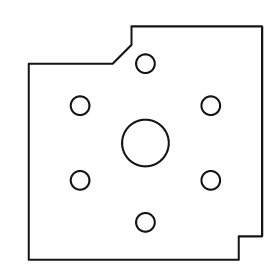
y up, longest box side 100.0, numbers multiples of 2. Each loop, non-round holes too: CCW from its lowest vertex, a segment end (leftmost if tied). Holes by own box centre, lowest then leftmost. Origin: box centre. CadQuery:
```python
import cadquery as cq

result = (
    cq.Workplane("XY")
    .moveTo(-50.0, -50.0)
    .lineTo(40.0, -50.0)
    .lineTo(40.0, -40.0)
    .lineTo(50.0, -40.0)
    .lineTo(50.0, 50.0)
    .lineTo(-6.0, 50.0)
    .lineTo(-6.0, 42.0)
    .lineTo(-14.0, 34.0)
    .lineTo(-50.0, 34.0)
    .close()
    .moveTo(0.0, -34.0)
    .circle(4.0)
    .moveTo(-28.0, -16.0)
    .circle(4.0)
    .moveTo(28.0, -16.0)
    .circle(4.0)
    .moveTo(0.0, 0.0)
    .circle(10.0)
    .moveTo(-28.0, 16.0)
    .circle(4.0)
    .moveTo(28.0, 16.0)
    .circle(4.0)
    .moveTo(0.0, 34.0)
    .circle(4.0)
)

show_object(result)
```